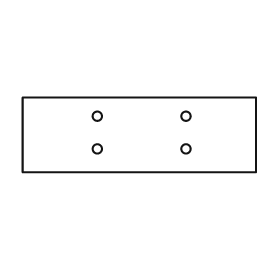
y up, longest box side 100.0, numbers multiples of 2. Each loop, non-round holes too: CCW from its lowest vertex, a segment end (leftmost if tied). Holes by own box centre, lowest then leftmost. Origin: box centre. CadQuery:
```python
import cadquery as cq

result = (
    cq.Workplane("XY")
    .moveTo(-50.0, -16.0)
    .lineTo(50.0, -16.0)
    .lineTo(50.0, 16.0)
    .lineTo(-50.0, 16.0)
    .close()
    .moveTo(-18.0, -6.0)
    .circle(2.0)
    .moveTo(20.0, -6.0)
    .circle(2.0)
    .moveTo(-18.0, 8.0)
    .circle(2.0)
    .moveTo(20.0, 8.0)
    .circle(2.0)
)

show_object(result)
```